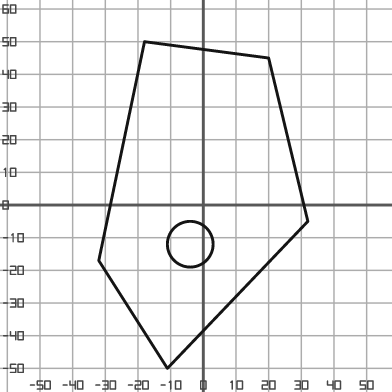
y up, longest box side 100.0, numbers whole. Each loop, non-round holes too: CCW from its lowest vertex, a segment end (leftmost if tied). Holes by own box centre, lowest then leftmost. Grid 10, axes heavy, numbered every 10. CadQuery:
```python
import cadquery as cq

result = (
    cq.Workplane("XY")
    .moveTo(-11.0, -50.0)
    .lineTo(32.0, -5.0)
    .lineTo(20.0, 45.0)
    .lineTo(-18.0, 50.0)
    .lineTo(-32.0, -17.0)
    .close()
    .moveTo(-4.0, -12.0)
    .circle(7.0)
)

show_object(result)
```